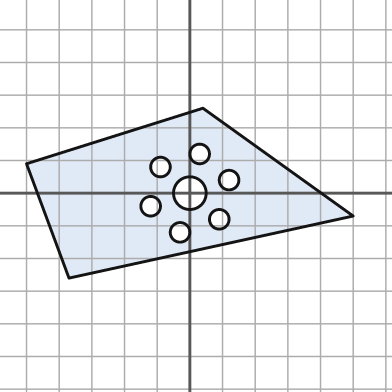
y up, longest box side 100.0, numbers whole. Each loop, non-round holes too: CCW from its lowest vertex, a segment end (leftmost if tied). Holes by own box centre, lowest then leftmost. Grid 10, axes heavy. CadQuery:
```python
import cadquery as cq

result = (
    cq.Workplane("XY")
    .moveTo(-37.0, -26.0)
    .lineTo(50.0, -7.0)
    .lineTo(4.0, 26.0)
    .lineTo(-50.0, 9.0)
    .close()
    .moveTo(-3.0, -12.0)
    .circle(3.0)
    .moveTo(9.0, -8.0)
    .circle(3.0)
    .moveTo(-12.0, -4.0)
    .circle(3.0)
    .moveTo(0.0, 0.0)
    .circle(5.0)
    .moveTo(12.0, 4.0)
    .circle(3.0)
    .moveTo(-9.0, 8.0)
    .circle(3.0)
    .moveTo(3.0, 12.0)
    .circle(3.0)
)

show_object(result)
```